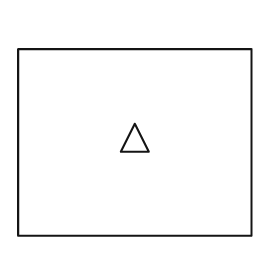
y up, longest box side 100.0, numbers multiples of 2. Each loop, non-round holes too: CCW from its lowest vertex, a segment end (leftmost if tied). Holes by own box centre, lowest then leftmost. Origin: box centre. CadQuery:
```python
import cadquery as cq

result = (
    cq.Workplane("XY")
    .moveTo(-50.0, -40.0)
    .lineTo(50.0, -40.0)
    .lineTo(50.0, 40.0)
    .lineTo(-50.0, 40.0)
    .close()
    .moveTo(-6.0, -4.0)
    .lineTo(6.0, -4.0)
    .lineTo(0.0, 8.0)
    .close()
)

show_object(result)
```